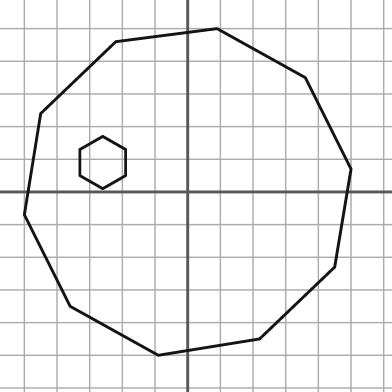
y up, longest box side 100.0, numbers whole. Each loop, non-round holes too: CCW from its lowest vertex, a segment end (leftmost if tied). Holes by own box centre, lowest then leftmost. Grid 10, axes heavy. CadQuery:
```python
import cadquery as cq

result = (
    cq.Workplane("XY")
    .moveTo(-9.0, -50.0)
    .lineTo(22.0, -45.0)
    .lineTo(45.0, -23.0)
    .lineTo(50.0, 7.0)
    .lineTo(36.0, 35.0)
    .lineTo(9.0, 50.0)
    .lineTo(-22.0, 46.0)
    .lineTo(-45.0, 24.0)
    .lineTo(-50.0, -7.0)
    .lineTo(-36.0, -35.0)
    .close()
    .moveTo(-26.0, 1.0)
    .lineTo(-19.0, 5.0)
    .lineTo(-19.0, 13.0)
    .lineTo(-26.0, 17.0)
    .lineTo(-33.0, 13.0)
    .lineTo(-33.0, 5.0)
    .close()
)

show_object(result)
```